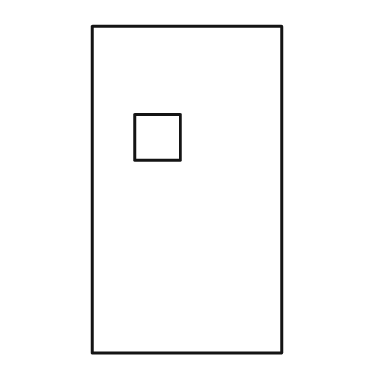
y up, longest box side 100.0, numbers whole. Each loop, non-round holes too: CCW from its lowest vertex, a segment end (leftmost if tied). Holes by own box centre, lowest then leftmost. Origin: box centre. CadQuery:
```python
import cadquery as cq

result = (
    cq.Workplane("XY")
    .moveTo(-29.0, -50.0)
    .lineTo(29.0, -50.0)
    .lineTo(29.0, 50.0)
    .lineTo(-29.0, 50.0)
    .close()
    .moveTo(-16.0, 9.0)
    .lineTo(-2.0, 9.0)
    .lineTo(-2.0, 23.0)
    .lineTo(-16.0, 23.0)
    .close()
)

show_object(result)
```